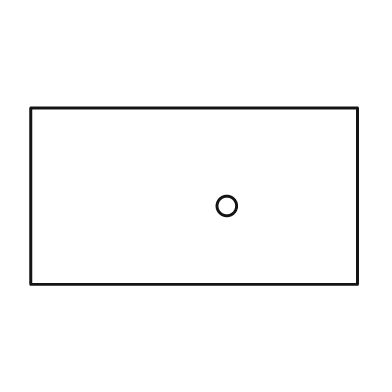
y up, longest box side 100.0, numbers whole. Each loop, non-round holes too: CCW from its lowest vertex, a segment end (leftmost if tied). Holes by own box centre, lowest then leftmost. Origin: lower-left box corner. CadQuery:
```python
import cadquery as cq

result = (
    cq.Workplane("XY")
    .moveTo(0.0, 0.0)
    .lineTo(100.0, 0.0)
    .lineTo(100.0, 54.0)
    .lineTo(0.0, 54.0)
    .close()
    .moveTo(60.0, 24.0)
    .circle(3.0)
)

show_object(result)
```